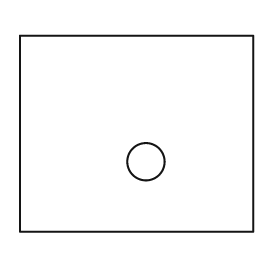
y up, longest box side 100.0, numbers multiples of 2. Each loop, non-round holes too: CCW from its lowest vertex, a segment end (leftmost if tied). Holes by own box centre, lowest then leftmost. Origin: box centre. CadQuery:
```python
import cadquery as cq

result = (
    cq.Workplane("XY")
    .moveTo(-50.0, -42.0)
    .lineTo(50.0, -42.0)
    .lineTo(50.0, 42.0)
    .lineTo(-50.0, 42.0)
    .close()
    .moveTo(4.0, -12.0)
    .circle(8.0)
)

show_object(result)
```